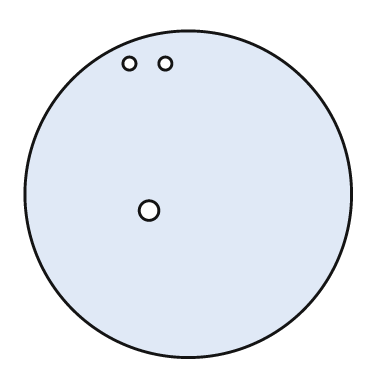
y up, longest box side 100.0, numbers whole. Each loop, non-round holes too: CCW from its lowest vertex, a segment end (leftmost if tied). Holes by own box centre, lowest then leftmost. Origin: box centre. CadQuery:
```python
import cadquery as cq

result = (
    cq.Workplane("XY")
    .moveTo(0.0, 0.0)
    .circle(50.0)
    .moveTo(-12.0, -5.0)
    .circle(3.0)
    .moveTo(-18.0, 40.0)
    .circle(2.0)
    .moveTo(-7.0, 40.0)
    .circle(2.0)
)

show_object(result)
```